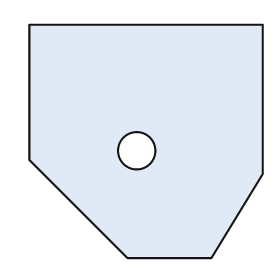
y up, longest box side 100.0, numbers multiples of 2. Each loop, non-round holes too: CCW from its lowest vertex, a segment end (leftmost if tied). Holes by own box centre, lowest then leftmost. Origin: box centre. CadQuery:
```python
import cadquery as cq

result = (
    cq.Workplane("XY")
    .moveTo(-8.0, -50.0)
    .lineTo(28.0, -50.0)
    .lineTo(50.0, -14.0)
    .lineTo(50.0, 50.0)
    .lineTo(-50.0, 50.0)
    .lineTo(-50.0, -8.0)
    .close()
    .moveTo(-4.0, -4.0)
    .circle(8.0)
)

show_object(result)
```